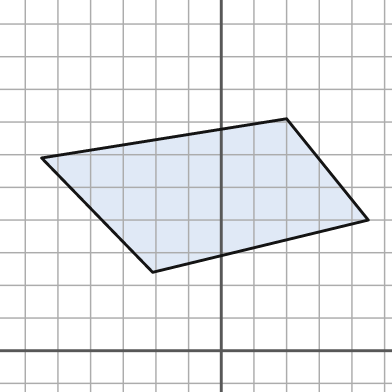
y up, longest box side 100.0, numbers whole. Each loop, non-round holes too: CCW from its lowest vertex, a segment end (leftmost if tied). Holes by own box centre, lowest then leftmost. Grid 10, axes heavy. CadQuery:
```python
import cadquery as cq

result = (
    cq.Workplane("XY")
    .moveTo(-21.0, 24.0)
    .lineTo(45.0, 40.0)
    .lineTo(20.0, 71.0)
    .lineTo(-55.0, 59.0)
    .close()
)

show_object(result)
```